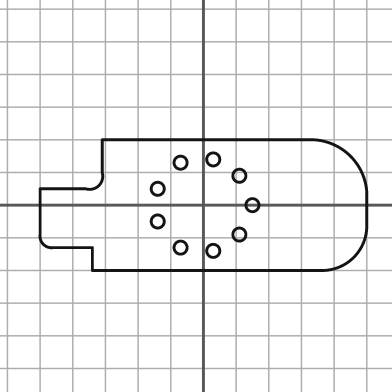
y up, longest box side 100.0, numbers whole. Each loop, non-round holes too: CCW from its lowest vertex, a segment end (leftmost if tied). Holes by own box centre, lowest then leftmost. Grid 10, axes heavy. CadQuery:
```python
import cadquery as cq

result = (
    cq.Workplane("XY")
    .moveTo(-34.0, -20.0)
    .lineTo(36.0, -20.0)
    .threePointArc((46.0, -16.0), (50.0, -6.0))
    .lineTo(50.0, 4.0)
    .threePointArc((45.0, 15.0), (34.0, 20.0))
    .lineTo(-31.0, 20.0)
    .lineTo(-31.0, 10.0)
    .threePointArc((-32.0, 6.0), (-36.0, 5.0))
    .lineTo(-50.0, 5.0)
    .lineTo(-50.0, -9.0)
    .threePointArc((-49.0, -12.0), (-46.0, -13.0))
    .lineTo(-34.0, -13.0)
    .close()
    .moveTo(3.0, -14.0)
    .circle(2.0)
    .moveTo(-7.0, -13.0)
    .circle(2.0)
    .moveTo(11.0, -9.0)
    .circle(2.0)
    .moveTo(-14.0, -5.0)
    .circle(2.0)
    .moveTo(15.0, 0.0)
    .circle(2.0)
    .moveTo(-14.0, 5.0)
    .circle(2.0)
    .moveTo(11.0, 9.0)
    .circle(2.0)
    .moveTo(-7.0, 13.0)
    .circle(2.0)
    .moveTo(3.0, 14.0)
    .circle(2.0)
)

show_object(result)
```